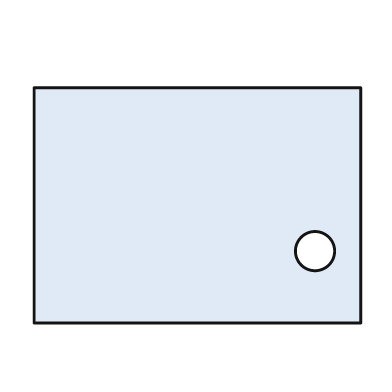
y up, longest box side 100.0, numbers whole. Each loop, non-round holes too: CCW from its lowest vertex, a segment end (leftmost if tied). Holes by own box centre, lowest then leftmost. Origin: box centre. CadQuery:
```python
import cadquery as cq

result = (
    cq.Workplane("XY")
    .moveTo(-50.0, -36.0)
    .lineTo(50.0, -36.0)
    .lineTo(50.0, 36.0)
    .lineTo(-50.0, 36.0)
    .close()
    .moveTo(36.0, -14.0)
    .circle(6.0)
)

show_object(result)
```